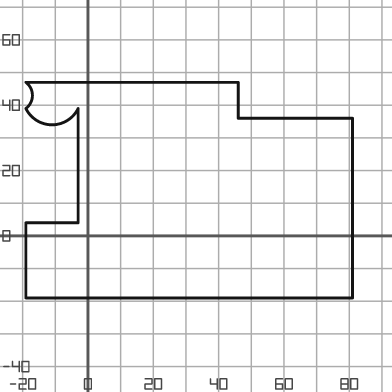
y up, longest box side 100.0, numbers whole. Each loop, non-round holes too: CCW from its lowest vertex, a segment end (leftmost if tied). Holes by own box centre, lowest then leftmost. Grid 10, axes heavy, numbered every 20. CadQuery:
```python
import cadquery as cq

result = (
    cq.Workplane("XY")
    .moveTo(-19.0, -19.0)
    .lineTo(81.0, -19.0)
    .lineTo(81.0, 36.0)
    .lineTo(46.0, 36.0)
    .lineTo(46.0, 47.0)
    .lineTo(-19.0, 47.0)
    .threePointArc((-17.0, 43.0), (-19.0, 39.0))
    .threePointArc((-11.0, 34.0), (-3.0, 39.0))
    .lineTo(-3.0, 4.0)
    .lineTo(-19.0, 4.0)
    .close()
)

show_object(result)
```